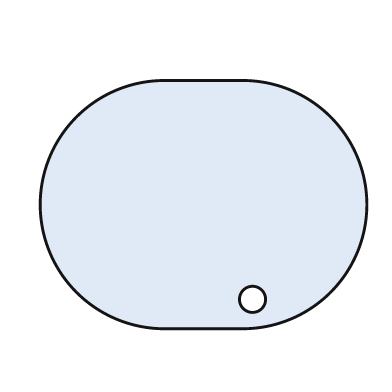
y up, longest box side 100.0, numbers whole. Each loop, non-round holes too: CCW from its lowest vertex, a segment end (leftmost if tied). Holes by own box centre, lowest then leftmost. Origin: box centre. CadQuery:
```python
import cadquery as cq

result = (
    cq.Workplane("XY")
    .moveTo(-12.0, -38.0)
    .lineTo(12.0, -38.0)
    .threePointArc((50.0, 0.0), (12.0, 38.0))
    .lineTo(-12.0, 38.0)
    .threePointArc((-50.0, 0.0), (-12.0, -38.0))
    .close()
    .moveTo(15.0, -29.0)
    .circle(4.0)
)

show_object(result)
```